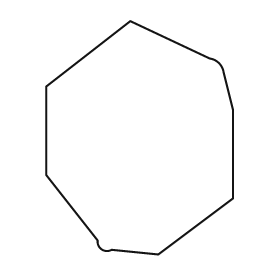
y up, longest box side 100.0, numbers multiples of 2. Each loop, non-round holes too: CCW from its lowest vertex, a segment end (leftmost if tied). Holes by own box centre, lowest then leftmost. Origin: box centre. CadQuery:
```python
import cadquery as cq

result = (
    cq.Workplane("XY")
    .moveTo(8.0, -50.0)
    .lineTo(40.0, -26.0)
    .lineTo(40.0, 12.0)
    .lineTo(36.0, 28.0)
    .threePointArc((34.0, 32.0), (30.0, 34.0))
    .lineTo(-4.0, 50.0)
    .lineTo(-40.0, 22.0)
    .lineTo(-40.0, -16.0)
    .lineTo(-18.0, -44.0)
    .threePointArc((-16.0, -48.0), (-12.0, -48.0))
    .close()
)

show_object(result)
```